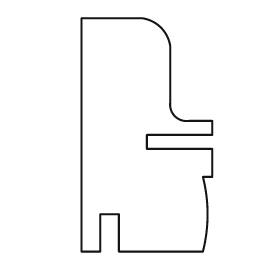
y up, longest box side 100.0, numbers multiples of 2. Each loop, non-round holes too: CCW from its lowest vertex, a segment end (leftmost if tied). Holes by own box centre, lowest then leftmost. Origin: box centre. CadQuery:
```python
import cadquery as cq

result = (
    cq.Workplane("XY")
    .moveTo(-28.0, -50.0)
    .lineTo(-20.0, -50.0)
    .lineTo(-20.0, -34.0)
    .lineTo(-12.0, -34.0)
    .lineTo(-12.0, -50.0)
    .lineTo(24.0, -50.0)
    .threePointArc((26.0, -34.0), (24.0, -18.0))
    .lineTo(28.0, -18.0)
    .lineTo(28.0, -6.0)
    .lineTo(0.0, -6.0)
    .lineTo(0.0, 0.0)
    .lineTo(28.0, 0.0)
    .lineTo(28.0, 6.0)
    .lineTo(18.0, 6.0)
    .threePointArc((12.0, 8.0), (10.0, 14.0))
    .lineTo(10.0, 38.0)
    .threePointArc((6.0, 46.0), (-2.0, 50.0))
    .lineTo(-28.0, 50.0)
    .close()
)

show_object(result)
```